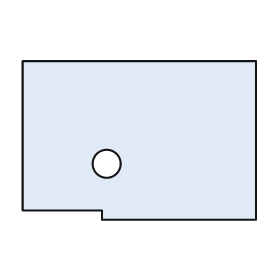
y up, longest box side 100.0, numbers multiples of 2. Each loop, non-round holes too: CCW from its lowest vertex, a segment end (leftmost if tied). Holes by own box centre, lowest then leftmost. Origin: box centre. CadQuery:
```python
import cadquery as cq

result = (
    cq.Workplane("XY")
    .moveTo(-16.0, -34.0)
    .lineTo(50.0, -34.0)
    .lineTo(50.0, 34.0)
    .lineTo(-50.0, 34.0)
    .lineTo(-50.0, -30.0)
    .lineTo(-16.0, -30.0)
    .close()
    .moveTo(-14.0, -10.0)
    .circle(6.0)
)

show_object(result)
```